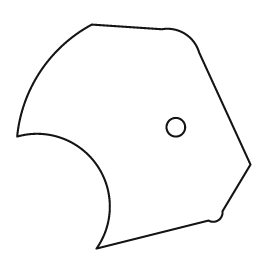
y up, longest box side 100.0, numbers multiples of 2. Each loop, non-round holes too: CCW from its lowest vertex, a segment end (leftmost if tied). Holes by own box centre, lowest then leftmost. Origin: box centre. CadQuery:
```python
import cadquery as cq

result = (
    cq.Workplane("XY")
    .moveTo(-16.0, -48.0)
    .lineTo(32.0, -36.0)
    .threePointArc((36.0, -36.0), (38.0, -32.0))
    .lineTo(50.0, -12.0)
    .lineTo(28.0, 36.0)
    .threePointArc((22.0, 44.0), (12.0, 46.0))
    .lineTo(-18.0, 48.0)
    .threePointArc((-40.0, 28.0), (-50.0, 0.0))
    .threePointArc((-16.0, -12.0), (-16.0, -48.0))
    .close()
    .moveTo(18.0, 4.0)
    .circle(4.0)
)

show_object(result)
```